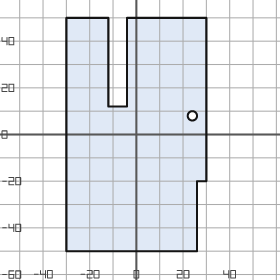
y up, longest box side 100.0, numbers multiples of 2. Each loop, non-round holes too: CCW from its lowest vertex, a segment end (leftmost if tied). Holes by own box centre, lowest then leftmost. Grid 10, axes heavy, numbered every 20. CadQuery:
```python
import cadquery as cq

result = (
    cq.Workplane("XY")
    .moveTo(-30.0, -50.0)
    .lineTo(26.0, -50.0)
    .lineTo(26.0, -20.0)
    .lineTo(30.0, -20.0)
    .lineTo(30.0, 50.0)
    .lineTo(-4.0, 50.0)
    .lineTo(-4.0, 12.0)
    .lineTo(-12.0, 12.0)
    .lineTo(-12.0, 50.0)
    .lineTo(-30.0, 50.0)
    .close()
    .moveTo(24.0, 8.0)
    .circle(2.0)
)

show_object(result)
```